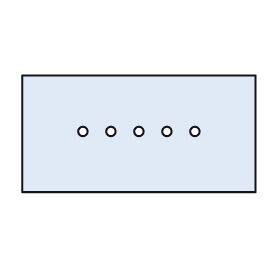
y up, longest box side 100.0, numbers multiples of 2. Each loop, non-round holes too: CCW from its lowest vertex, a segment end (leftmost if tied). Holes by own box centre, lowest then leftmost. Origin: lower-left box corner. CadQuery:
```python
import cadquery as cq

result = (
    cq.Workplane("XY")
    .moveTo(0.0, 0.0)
    .lineTo(100.0, 0.0)
    .lineTo(100.0, 50.0)
    .lineTo(0.0, 50.0)
    .close()
    .moveTo(26.0, 26.0)
    .circle(2.0)
    .moveTo(38.0, 26.0)
    .circle(2.0)
    .moveTo(50.0, 26.0)
    .circle(2.0)
    .moveTo(62.0, 26.0)
    .circle(2.0)
    .moveTo(74.0, 26.0)
    .circle(2.0)
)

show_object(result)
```